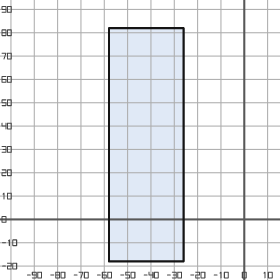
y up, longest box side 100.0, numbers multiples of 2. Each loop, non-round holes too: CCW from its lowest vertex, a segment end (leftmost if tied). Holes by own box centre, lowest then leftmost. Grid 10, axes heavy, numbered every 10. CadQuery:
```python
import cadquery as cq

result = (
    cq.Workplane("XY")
    .moveTo(-58.0, -18.0)
    .lineTo(-26.0, -18.0)
    .lineTo(-26.0, 82.0)
    .lineTo(-58.0, 82.0)
    .close()
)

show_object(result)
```